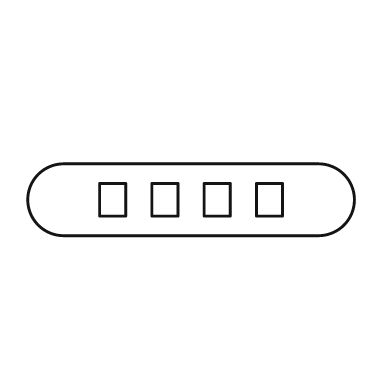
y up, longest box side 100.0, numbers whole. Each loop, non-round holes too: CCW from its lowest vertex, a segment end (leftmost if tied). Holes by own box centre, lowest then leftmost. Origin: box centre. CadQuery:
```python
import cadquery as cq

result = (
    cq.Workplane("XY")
    .moveTo(-39.0, -11.0)
    .lineTo(39.0, -11.0)
    .threePointArc((50.0, 0.0), (39.0, 11.0))
    .lineTo(-39.0, 11.0)
    .threePointArc((-50.0, 0.0), (-39.0, -11.0))
    .close()
    .moveTo(-28.0, -5.0)
    .lineTo(-20.0, -5.0)
    .lineTo(-20.0, 5.0)
    .lineTo(-28.0, 5.0)
    .close()
    .moveTo(-12.0, -5.0)
    .lineTo(-4.0, -5.0)
    .lineTo(-4.0, 5.0)
    .lineTo(-12.0, 5.0)
    .close()
    .moveTo(4.0, -5.0)
    .lineTo(12.0, -5.0)
    .lineTo(12.0, 5.0)
    .lineTo(4.0, 5.0)
    .close()
    .moveTo(20.0, -5.0)
    .lineTo(28.0, -5.0)
    .lineTo(28.0, 5.0)
    .lineTo(20.0, 5.0)
    .close()
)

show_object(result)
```